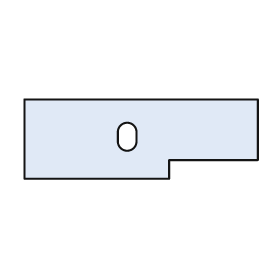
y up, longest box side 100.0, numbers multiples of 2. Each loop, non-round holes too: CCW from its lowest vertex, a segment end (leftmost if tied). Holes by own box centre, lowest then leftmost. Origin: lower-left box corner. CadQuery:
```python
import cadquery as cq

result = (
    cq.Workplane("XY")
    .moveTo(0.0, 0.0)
    .lineTo(62.0, 0.0)
    .lineTo(62.0, 8.0)
    .lineTo(100.0, 8.0)
    .lineTo(100.0, 34.0)
    .lineTo(0.0, 34.0)
    .close()
    .moveTo(40.0, 16.0)
    .threePointArc((44.0, 12.0), (48.0, 16.0))
    .lineTo(48.0, 20.0)
    .threePointArc((44.0, 24.0), (40.0, 20.0))
    .close()
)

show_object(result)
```